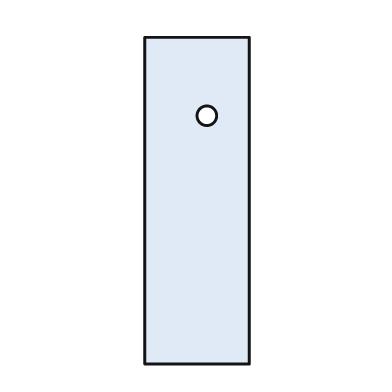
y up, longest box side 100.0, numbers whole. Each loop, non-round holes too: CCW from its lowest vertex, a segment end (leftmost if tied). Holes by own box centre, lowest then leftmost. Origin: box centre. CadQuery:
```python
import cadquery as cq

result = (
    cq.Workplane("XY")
    .moveTo(-16.0, -50.0)
    .lineTo(16.0, -50.0)
    .lineTo(16.0, 50.0)
    .lineTo(-16.0, 50.0)
    .close()
    .moveTo(3.0, 26.0)
    .circle(3.0)
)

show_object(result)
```